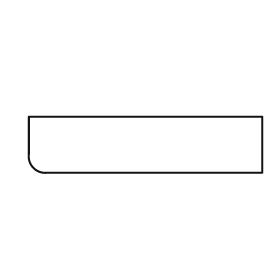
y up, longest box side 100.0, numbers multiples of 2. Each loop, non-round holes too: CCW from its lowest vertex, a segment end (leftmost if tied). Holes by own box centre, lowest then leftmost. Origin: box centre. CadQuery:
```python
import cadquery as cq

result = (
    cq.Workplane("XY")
    .moveTo(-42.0, -12.0)
    .lineTo(50.0, -12.0)
    .lineTo(50.0, 12.0)
    .lineTo(-50.0, 12.0)
    .lineTo(-50.0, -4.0)
    .threePointArc((-48.0, -10.0), (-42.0, -12.0))
    .close()
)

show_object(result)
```